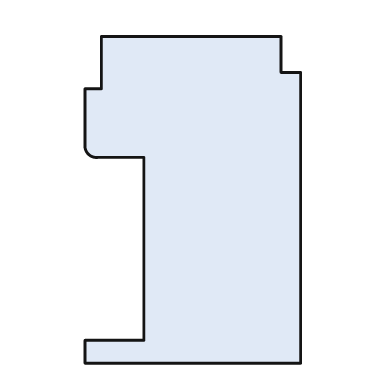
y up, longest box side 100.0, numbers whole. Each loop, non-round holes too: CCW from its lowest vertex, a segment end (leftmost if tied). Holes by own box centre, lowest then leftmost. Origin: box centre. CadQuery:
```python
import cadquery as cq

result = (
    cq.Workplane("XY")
    .moveTo(-33.0, -50.0)
    .lineTo(33.0, -50.0)
    .lineTo(33.0, 39.0)
    .lineTo(27.0, 39.0)
    .lineTo(27.0, 50.0)
    .lineTo(-28.0, 50.0)
    .lineTo(-28.0, 34.0)
    .lineTo(-33.0, 34.0)
    .lineTo(-33.0, 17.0)
    .threePointArc((-32.0, 14.0), (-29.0, 13.0))
    .lineTo(-15.0, 13.0)
    .lineTo(-15.0, -43.0)
    .lineTo(-33.0, -43.0)
    .close()
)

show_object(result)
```